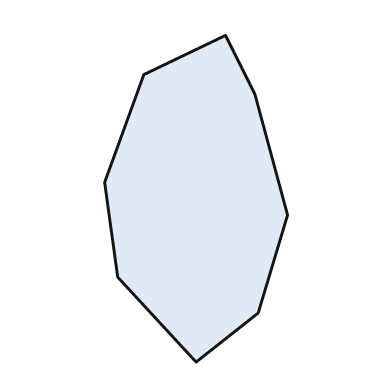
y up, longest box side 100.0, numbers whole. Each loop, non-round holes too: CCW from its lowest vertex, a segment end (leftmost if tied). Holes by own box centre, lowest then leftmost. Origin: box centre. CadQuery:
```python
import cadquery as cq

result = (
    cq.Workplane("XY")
    .moveTo(0.0, -50.0)
    .lineTo(19.0, -35.0)
    .lineTo(28.0, -5.0)
    .lineTo(18.0, 32.0)
    .lineTo(9.0, 50.0)
    .lineTo(-16.0, 38.0)
    .lineTo(-28.0, 5.0)
    .lineTo(-24.0, -24.0)
    .close()
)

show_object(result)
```